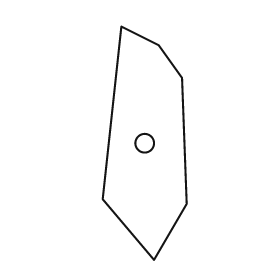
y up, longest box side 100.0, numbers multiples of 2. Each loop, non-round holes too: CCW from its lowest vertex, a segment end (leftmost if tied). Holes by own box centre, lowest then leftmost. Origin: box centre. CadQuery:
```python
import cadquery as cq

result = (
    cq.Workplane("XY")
    .moveTo(4.0, -50.0)
    .lineTo(18.0, -26.0)
    .lineTo(16.0, 28.0)
    .lineTo(6.0, 42.0)
    .lineTo(-10.0, 50.0)
    .lineTo(-18.0, -24.0)
    .close()
    .moveTo(0.0, 0.0)
    .circle(4.0)
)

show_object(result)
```